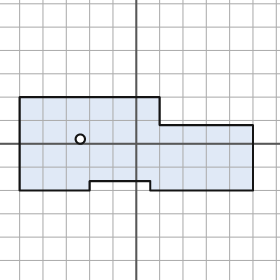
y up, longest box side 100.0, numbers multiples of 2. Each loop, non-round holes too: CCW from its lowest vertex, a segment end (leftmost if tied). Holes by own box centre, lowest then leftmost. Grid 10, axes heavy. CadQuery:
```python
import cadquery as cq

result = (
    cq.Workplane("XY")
    .moveTo(-50.0, -20.0)
    .lineTo(-20.0, -20.0)
    .lineTo(-20.0, -16.0)
    .lineTo(6.0, -16.0)
    .lineTo(6.0, -20.0)
    .lineTo(50.0, -20.0)
    .lineTo(50.0, 8.0)
    .lineTo(10.0, 8.0)
    .lineTo(10.0, 20.0)
    .lineTo(-50.0, 20.0)
    .close()
    .moveTo(-24.0, 2.0)
    .circle(2.0)
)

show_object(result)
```